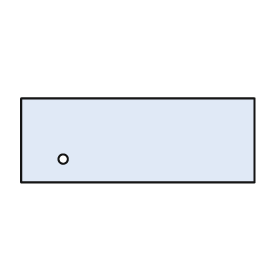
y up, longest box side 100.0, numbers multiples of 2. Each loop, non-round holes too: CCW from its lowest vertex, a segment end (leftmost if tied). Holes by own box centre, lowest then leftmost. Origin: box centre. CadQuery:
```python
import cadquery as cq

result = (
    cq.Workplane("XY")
    .moveTo(-50.0, -18.0)
    .lineTo(50.0, -18.0)
    .lineTo(50.0, 18.0)
    .lineTo(-50.0, 18.0)
    .close()
    .moveTo(-32.0, -8.0)
    .circle(2.0)
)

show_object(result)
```